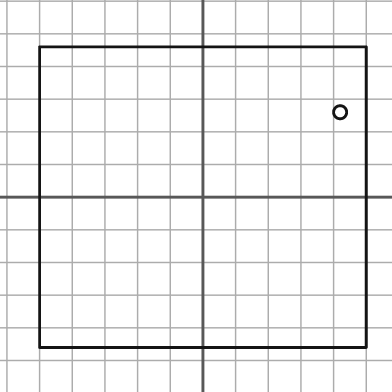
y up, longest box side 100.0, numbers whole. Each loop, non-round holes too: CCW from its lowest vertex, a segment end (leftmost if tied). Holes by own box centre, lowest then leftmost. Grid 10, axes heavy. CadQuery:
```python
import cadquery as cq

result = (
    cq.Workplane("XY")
    .moveTo(-50.0, -46.0)
    .lineTo(50.0, -46.0)
    .lineTo(50.0, 46.0)
    .lineTo(-50.0, 46.0)
    .close()
    .moveTo(42.0, 26.0)
    .circle(2.0)
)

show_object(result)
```